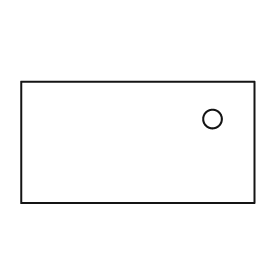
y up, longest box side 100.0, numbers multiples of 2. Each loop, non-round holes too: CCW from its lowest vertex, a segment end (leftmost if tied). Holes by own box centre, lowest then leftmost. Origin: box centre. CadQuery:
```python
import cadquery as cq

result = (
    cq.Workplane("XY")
    .moveTo(-50.0, -26.0)
    .lineTo(50.0, -26.0)
    .lineTo(50.0, 26.0)
    .lineTo(-50.0, 26.0)
    .close()
    .moveTo(32.0, 10.0)
    .circle(4.0)
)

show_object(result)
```